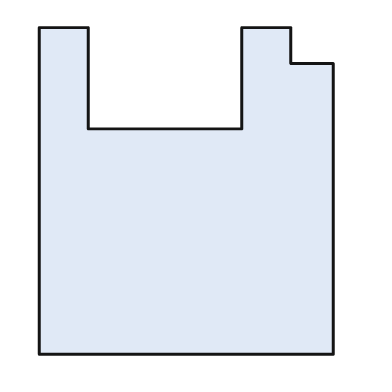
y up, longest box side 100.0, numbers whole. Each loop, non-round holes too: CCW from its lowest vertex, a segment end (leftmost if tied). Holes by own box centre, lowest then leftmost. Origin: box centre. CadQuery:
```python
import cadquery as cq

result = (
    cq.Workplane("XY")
    .moveTo(-45.0, -50.0)
    .lineTo(45.0, -50.0)
    .lineTo(45.0, 39.0)
    .lineTo(32.0, 39.0)
    .lineTo(32.0, 50.0)
    .lineTo(17.0, 50.0)
    .lineTo(17.0, 19.0)
    .lineTo(-30.0, 19.0)
    .lineTo(-30.0, 50.0)
    .lineTo(-45.0, 50.0)
    .close()
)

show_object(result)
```